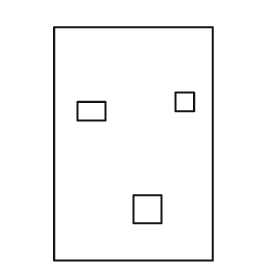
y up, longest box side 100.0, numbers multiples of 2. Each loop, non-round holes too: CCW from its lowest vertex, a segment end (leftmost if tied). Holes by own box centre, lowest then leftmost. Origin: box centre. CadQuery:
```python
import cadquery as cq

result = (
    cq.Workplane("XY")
    .moveTo(-34.0, -50.0)
    .lineTo(34.0, -50.0)
    .lineTo(34.0, 50.0)
    .lineTo(-34.0, 50.0)
    .close()
    .moveTo(0.0, -34.0)
    .lineTo(12.0, -34.0)
    .lineTo(12.0, -22.0)
    .lineTo(0.0, -22.0)
    .close()
    .moveTo(-24.0, 10.0)
    .lineTo(-12.0, 10.0)
    .lineTo(-12.0, 18.0)
    .lineTo(-24.0, 18.0)
    .close()
    .moveTo(18.0, 14.0)
    .lineTo(26.0, 14.0)
    .lineTo(26.0, 22.0)
    .lineTo(18.0, 22.0)
    .close()
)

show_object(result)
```